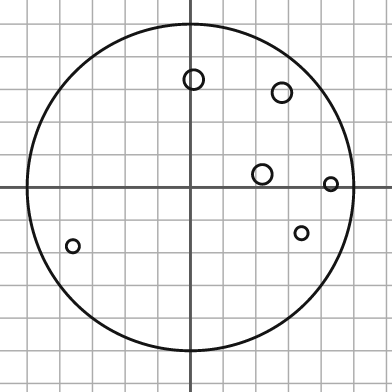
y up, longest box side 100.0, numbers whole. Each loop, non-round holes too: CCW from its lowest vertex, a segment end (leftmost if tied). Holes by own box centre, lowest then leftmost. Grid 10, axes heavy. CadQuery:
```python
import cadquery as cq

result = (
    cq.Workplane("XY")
    .moveTo(0.0, 0.0)
    .circle(50.0)
    .moveTo(-36.0, -18.0)
    .circle(2.0)
    .moveTo(34.0, -14.0)
    .circle(2.0)
    .moveTo(43.0, 1.0)
    .circle(2.0)
    .moveTo(22.0, 4.0)
    .circle(3.0)
    .moveTo(28.0, 29.0)
    .circle(3.0)
    .moveTo(1.0, 33.0)
    .circle(3.0)
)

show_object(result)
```